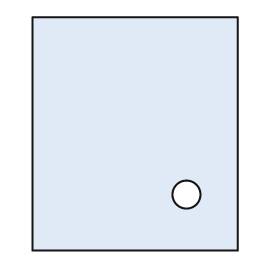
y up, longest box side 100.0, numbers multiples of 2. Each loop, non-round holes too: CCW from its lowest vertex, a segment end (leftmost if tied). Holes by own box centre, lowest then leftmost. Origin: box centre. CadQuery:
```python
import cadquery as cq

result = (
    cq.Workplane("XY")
    .moveTo(-44.0, -50.0)
    .lineTo(44.0, -50.0)
    .lineTo(44.0, 50.0)
    .lineTo(-44.0, 50.0)
    .close()
    .moveTo(22.0, -26.0)
    .circle(6.0)
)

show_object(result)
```